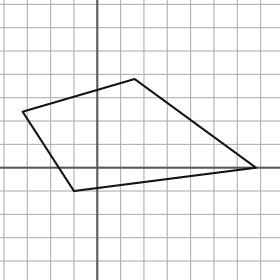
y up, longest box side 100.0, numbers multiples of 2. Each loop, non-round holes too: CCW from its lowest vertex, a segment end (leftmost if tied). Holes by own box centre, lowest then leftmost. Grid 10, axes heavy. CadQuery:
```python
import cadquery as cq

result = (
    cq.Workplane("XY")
    .moveTo(-10.0, -10.0)
    .lineTo(68.0, 0.0)
    .lineTo(16.0, 38.0)
    .lineTo(-32.0, 24.0)
    .close()
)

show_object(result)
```